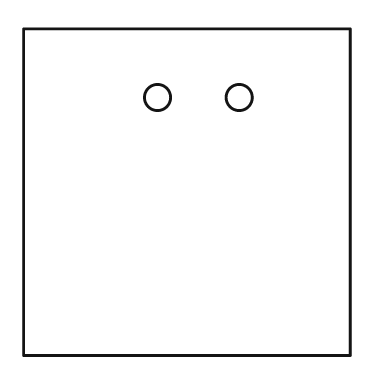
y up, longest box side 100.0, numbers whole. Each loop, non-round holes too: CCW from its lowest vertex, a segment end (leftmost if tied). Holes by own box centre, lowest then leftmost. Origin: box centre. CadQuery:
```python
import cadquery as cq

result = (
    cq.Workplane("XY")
    .moveTo(-50.0, -50.0)
    .lineTo(50.0, -50.0)
    .lineTo(50.0, 50.0)
    .lineTo(-50.0, 50.0)
    .close()
    .moveTo(-9.0, 29.0)
    .circle(4.0)
    .moveTo(16.0, 29.0)
    .circle(4.0)
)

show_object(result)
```